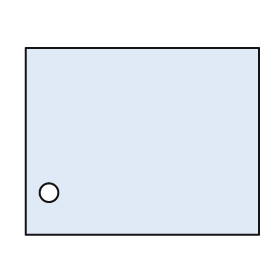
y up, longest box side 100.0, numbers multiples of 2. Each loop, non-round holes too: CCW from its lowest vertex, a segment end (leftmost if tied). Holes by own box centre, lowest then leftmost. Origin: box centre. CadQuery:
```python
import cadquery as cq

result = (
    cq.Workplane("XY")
    .moveTo(-50.0, -40.0)
    .lineTo(50.0, -40.0)
    .lineTo(50.0, 40.0)
    .lineTo(-50.0, 40.0)
    .close()
    .moveTo(-40.0, -22.0)
    .circle(4.0)
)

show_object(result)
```